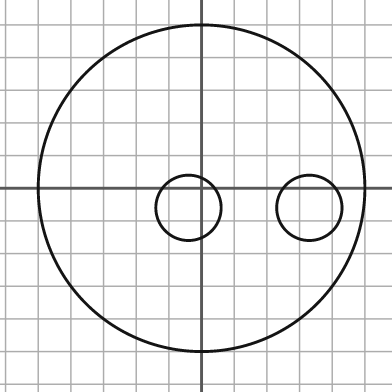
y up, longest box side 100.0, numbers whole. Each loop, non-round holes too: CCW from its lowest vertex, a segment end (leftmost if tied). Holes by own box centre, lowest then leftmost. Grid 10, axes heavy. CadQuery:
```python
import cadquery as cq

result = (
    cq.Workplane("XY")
    .moveTo(0.0, 0.0)
    .circle(50.0)
    .moveTo(-4.0, -6.0)
    .circle(10.0)
    .moveTo(33.0, -6.0)
    .circle(10.0)
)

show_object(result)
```